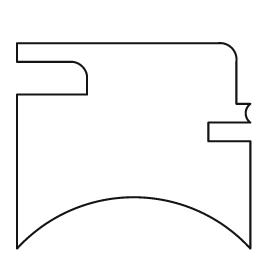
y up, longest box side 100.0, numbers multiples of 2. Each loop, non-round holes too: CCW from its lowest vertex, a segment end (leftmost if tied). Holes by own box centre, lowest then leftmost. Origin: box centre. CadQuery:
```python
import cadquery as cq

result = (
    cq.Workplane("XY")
    .moveTo(-50.0, -44.0)
    .threePointArc((0.0, -22.0), (50.0, -44.0))
    .lineTo(50.0, 2.0)
    .lineTo(32.0, 2.0)
    .lineTo(32.0, 10.0)
    .lineTo(50.0, 10.0)
    .threePointArc((48.0, 14.0), (50.0, 18.0))
    .lineTo(44.0, 18.0)
    .lineTo(44.0, 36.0)
    .threePointArc((42.0, 42.0), (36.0, 44.0))
    .lineTo(-50.0, 44.0)
    .lineTo(-50.0, 36.0)
    .lineTo(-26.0, 36.0)
    .threePointArc((-22.0, 34.0), (-20.0, 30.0))
    .lineTo(-20.0, 22.0)
    .lineTo(-50.0, 22.0)
    .close()
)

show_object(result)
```